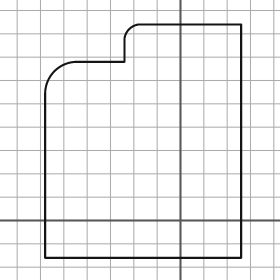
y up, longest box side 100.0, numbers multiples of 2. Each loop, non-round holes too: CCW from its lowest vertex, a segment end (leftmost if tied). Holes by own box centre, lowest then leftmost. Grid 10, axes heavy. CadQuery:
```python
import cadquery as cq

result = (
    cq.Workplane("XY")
    .moveTo(-58.0, -16.0)
    .lineTo(26.0, -16.0)
    .lineTo(26.0, 84.0)
    .lineTo(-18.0, 84.0)
    .threePointArc((-22.0, 82.0), (-24.0, 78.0))
    .lineTo(-24.0, 68.0)
    .lineTo(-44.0, 68.0)
    .threePointArc((-54.0, 64.0), (-58.0, 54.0))
    .close()
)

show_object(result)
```